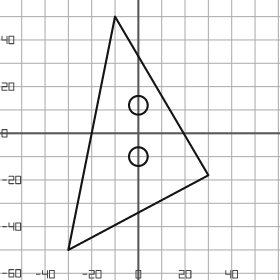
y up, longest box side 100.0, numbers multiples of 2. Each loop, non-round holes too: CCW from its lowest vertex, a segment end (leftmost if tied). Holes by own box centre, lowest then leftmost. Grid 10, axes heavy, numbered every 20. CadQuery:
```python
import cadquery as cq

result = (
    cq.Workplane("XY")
    .moveTo(-30.0, -50.0)
    .lineTo(30.0, -18.0)
    .lineTo(-10.0, 50.0)
    .close()
    .moveTo(0.0, -10.0)
    .circle(4.0)
    .moveTo(0.0, 12.0)
    .circle(4.0)
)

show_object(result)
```